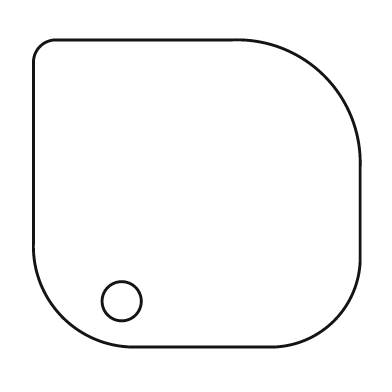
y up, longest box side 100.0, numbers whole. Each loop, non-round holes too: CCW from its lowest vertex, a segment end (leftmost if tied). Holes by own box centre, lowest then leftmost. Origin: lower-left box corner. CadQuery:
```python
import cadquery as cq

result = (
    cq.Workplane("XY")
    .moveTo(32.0, 0.0)
    .lineTo(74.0, 0.0)
    .threePointArc((92.0, 8.0), (100.0, 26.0))
    .lineTo(100.0, 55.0)
    .threePointArc((89.0, 83.0), (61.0, 94.0))
    .lineTo(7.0, 94.0)
    .threePointArc((2.0, 92.0), (0.0, 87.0))
    .lineTo(0.0, 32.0)
    .threePointArc((9.0, 9.0), (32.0, 0.0))
    .close()
    .moveTo(27.0, 14.0)
    .circle(6.0)
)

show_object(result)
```